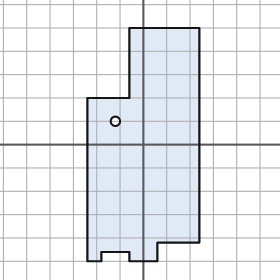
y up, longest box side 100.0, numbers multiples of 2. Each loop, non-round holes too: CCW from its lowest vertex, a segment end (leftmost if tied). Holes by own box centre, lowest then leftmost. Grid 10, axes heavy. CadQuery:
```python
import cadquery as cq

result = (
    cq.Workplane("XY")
    .moveTo(-24.0, -50.0)
    .lineTo(-18.0, -50.0)
    .lineTo(-18.0, -46.0)
    .lineTo(-6.0, -46.0)
    .lineTo(-6.0, -50.0)
    .lineTo(6.0, -50.0)
    .lineTo(6.0, -42.0)
    .lineTo(24.0, -42.0)
    .lineTo(24.0, 50.0)
    .lineTo(-6.0, 50.0)
    .lineTo(-6.0, 20.0)
    .lineTo(-24.0, 20.0)
    .close()
    .moveTo(-12.0, 10.0)
    .circle(2.0)
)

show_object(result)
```